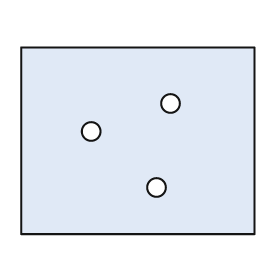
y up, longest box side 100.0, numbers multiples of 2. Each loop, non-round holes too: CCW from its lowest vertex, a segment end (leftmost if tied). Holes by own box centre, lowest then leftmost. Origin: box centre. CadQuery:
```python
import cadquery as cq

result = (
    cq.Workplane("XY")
    .moveTo(-50.0, -40.0)
    .lineTo(50.0, -40.0)
    .lineTo(50.0, 40.0)
    .lineTo(-50.0, 40.0)
    .close()
    .moveTo(8.0, -20.0)
    .circle(4.0)
    .moveTo(-20.0, 4.0)
    .circle(4.0)
    .moveTo(14.0, 16.0)
    .circle(4.0)
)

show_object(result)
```